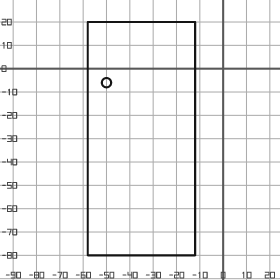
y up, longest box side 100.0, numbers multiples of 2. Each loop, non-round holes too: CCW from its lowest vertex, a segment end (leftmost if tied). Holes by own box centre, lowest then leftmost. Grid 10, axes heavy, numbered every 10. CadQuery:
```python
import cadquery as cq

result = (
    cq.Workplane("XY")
    .moveTo(-58.0, -80.0)
    .lineTo(-12.0, -80.0)
    .lineTo(-12.0, 20.0)
    .lineTo(-58.0, 20.0)
    .close()
    .moveTo(-50.0, -6.0)
    .circle(2.0)
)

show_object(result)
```